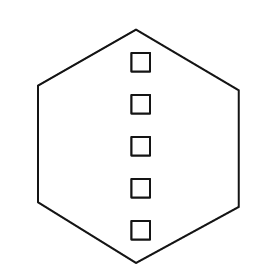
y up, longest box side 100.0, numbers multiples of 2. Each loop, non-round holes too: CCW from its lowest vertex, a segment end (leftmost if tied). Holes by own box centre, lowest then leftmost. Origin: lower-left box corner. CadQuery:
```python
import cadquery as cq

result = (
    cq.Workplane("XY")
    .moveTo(42.0, 0.0)
    .lineTo(86.0, 24.0)
    .lineTo(86.0, 74.0)
    .lineTo(42.0, 100.0)
    .lineTo(0.0, 76.0)
    .lineTo(0.0, 26.0)
    .close()
    .moveTo(40.0, 10.0)
    .lineTo(48.0, 10.0)
    .lineTo(48.0, 18.0)
    .lineTo(40.0, 18.0)
    .close()
    .moveTo(40.0, 28.0)
    .lineTo(48.0, 28.0)
    .lineTo(48.0, 36.0)
    .lineTo(40.0, 36.0)
    .close()
    .moveTo(40.0, 46.0)
    .lineTo(48.0, 46.0)
    .lineTo(48.0, 54.0)
    .lineTo(40.0, 54.0)
    .close()
    .moveTo(40.0, 64.0)
    .lineTo(48.0, 64.0)
    .lineTo(48.0, 72.0)
    .lineTo(40.0, 72.0)
    .close()
    .moveTo(40.0, 82.0)
    .lineTo(48.0, 82.0)
    .lineTo(48.0, 90.0)
    .lineTo(40.0, 90.0)
    .close()
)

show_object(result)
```